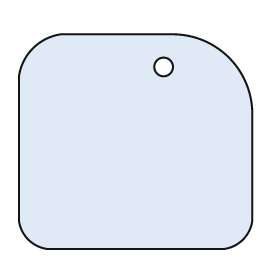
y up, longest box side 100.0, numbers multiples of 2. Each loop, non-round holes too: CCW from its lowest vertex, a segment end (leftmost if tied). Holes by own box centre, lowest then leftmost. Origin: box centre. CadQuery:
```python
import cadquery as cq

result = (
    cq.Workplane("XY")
    .moveTo(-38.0, -46.0)
    .lineTo(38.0, -46.0)
    .threePointArc((46.0, -42.0), (50.0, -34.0))
    .lineTo(50.0, 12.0)
    .threePointArc((40.0, 36.0), (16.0, 46.0))
    .lineTo(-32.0, 46.0)
    .threePointArc((-44.0, 40.0), (-50.0, 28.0))
    .lineTo(-50.0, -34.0)
    .threePointArc((-46.0, -42.0), (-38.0, -46.0))
    .close()
    .moveTo(12.0, 32.0)
    .circle(4.0)
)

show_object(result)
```